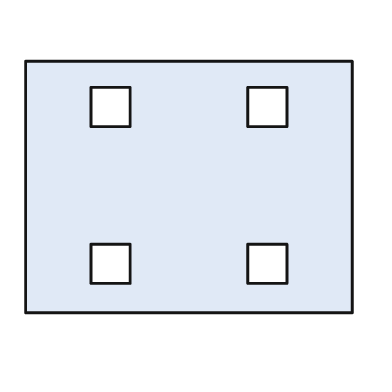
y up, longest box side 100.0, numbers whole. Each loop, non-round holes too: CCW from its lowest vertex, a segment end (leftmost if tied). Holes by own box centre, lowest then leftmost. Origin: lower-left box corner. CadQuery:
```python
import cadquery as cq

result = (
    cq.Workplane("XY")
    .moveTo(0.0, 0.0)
    .lineTo(100.0, 0.0)
    .lineTo(100.0, 77.0)
    .lineTo(0.0, 77.0)
    .close()
    .moveTo(20.0, 9.0)
    .lineTo(32.0, 9.0)
    .lineTo(32.0, 21.0)
    .lineTo(20.0, 21.0)
    .close()
    .moveTo(68.0, 9.0)
    .lineTo(80.0, 9.0)
    .lineTo(80.0, 21.0)
    .lineTo(68.0, 21.0)
    .close()
    .moveTo(20.0, 57.0)
    .lineTo(32.0, 57.0)
    .lineTo(32.0, 69.0)
    .lineTo(20.0, 69.0)
    .close()
    .moveTo(68.0, 57.0)
    .lineTo(80.0, 57.0)
    .lineTo(80.0, 69.0)
    .lineTo(68.0, 69.0)
    .close()
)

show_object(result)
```